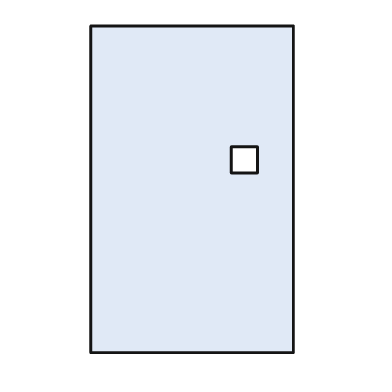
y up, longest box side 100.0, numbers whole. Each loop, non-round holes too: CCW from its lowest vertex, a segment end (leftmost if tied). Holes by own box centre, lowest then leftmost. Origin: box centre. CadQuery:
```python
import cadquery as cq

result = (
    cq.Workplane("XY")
    .moveTo(-31.0, -50.0)
    .lineTo(31.0, -50.0)
    .lineTo(31.0, 50.0)
    .lineTo(-31.0, 50.0)
    .close()
    .moveTo(12.0, 5.0)
    .lineTo(20.0, 5.0)
    .lineTo(20.0, 13.0)
    .lineTo(12.0, 13.0)
    .close()
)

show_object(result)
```